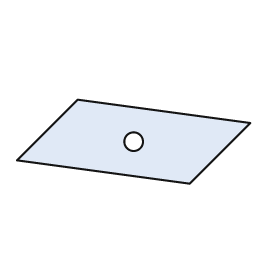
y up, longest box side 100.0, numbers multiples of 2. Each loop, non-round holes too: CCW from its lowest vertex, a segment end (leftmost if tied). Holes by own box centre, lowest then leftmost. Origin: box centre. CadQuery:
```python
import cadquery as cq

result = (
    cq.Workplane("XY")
    .moveTo(24.0, -18.0)
    .lineTo(50.0, 8.0)
    .lineTo(-24.0, 18.0)
    .lineTo(-50.0, -8.0)
    .close()
    .moveTo(0.0, 0.0)
    .circle(4.0)
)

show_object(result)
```